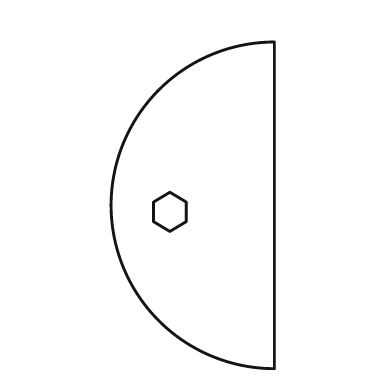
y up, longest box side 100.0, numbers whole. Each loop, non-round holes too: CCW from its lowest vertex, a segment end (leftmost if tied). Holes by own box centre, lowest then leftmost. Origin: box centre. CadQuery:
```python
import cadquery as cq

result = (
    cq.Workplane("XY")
    .moveTo(25.0, -50.0)
    .lineTo(25.0, 50.0)
    .threePointArc((-25.0, 0.0), (25.0, -50.0))
    .close()
    .moveTo(-7.0, -8.0)
    .lineTo(-2.0, -5.0)
    .lineTo(-2.0, 1.0)
    .lineTo(-7.0, 4.0)
    .lineTo(-12.0, 1.0)
    .lineTo(-12.0, -5.0)
    .close()
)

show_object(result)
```